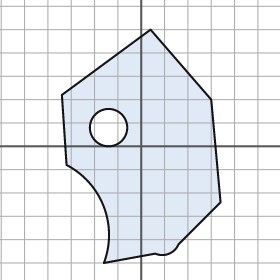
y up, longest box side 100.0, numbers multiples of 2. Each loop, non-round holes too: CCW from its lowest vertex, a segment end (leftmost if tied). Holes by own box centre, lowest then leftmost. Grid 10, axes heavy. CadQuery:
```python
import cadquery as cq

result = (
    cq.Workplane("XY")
    .moveTo(-16.0, -50.0)
    .lineTo(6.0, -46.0)
    .threePointArc((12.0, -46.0), (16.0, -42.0))
    .lineTo(34.0, -24.0)
    .lineTo(30.0, 20.0)
    .lineTo(4.0, 50.0)
    .lineTo(-34.0, 22.0)
    .lineTo(-32.0, -8.0)
    .threePointArc((-16.0, -26.0), (-16.0, -50.0))
    .close()
    .moveTo(-14.0, 8.0)
    .circle(8.0)
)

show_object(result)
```